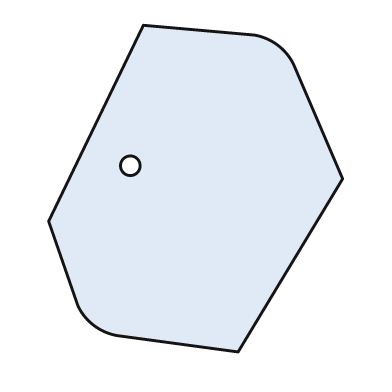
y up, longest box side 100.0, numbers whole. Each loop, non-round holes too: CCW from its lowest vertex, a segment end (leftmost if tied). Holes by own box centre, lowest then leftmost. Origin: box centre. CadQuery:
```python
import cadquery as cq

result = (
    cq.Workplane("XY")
    .moveTo(13.0, -50.0)
    .lineTo(45.0, 3.0)
    .lineTo(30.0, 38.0)
    .threePointArc((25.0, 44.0), (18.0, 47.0))
    .lineTo(-16.0, 50.0)
    .lineTo(-45.0, -10.0)
    .lineTo(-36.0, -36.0)
    .threePointArc((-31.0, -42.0), (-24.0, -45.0))
    .close()
    .moveTo(-20.0, 7.0)
    .circle(3.0)
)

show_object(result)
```